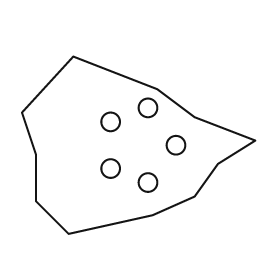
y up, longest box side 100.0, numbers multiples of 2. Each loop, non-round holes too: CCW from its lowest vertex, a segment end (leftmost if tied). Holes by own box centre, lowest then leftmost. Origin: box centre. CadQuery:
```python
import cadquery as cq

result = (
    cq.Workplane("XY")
    .moveTo(-30.0, -38.0)
    .lineTo(6.0, -30.0)
    .lineTo(24.0, -22.0)
    .lineTo(34.0, -8.0)
    .lineTo(50.0, 2.0)
    .lineTo(24.0, 12.0)
    .lineTo(8.0, 24.0)
    .lineTo(-28.0, 38.0)
    .lineTo(-50.0, 14.0)
    .lineTo(-44.0, -4.0)
    .lineTo(-44.0, -24.0)
    .close()
    .moveTo(4.0, -16.0)
    .circle(4.0)
    .moveTo(-12.0, -10.0)
    .circle(4.0)
    .moveTo(16.0, 0.0)
    .circle(4.0)
    .moveTo(-12.0, 10.0)
    .circle(4.0)
    .moveTo(4.0, 16.0)
    .circle(4.0)
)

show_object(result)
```